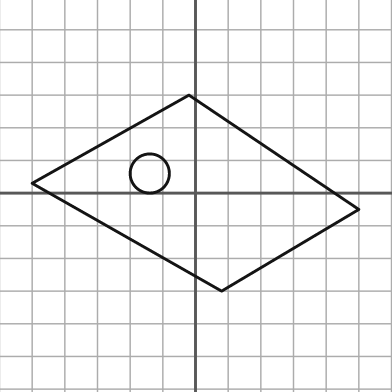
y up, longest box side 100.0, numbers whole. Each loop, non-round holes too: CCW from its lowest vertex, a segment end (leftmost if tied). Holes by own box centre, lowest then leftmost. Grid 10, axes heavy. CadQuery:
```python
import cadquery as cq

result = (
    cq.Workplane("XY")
    .moveTo(8.0, -30.0)
    .lineTo(50.0, -5.0)
    .lineTo(-2.0, 30.0)
    .lineTo(-50.0, 3.0)
    .close()
    .moveTo(-14.0, 6.0)
    .circle(6.0)
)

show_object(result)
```